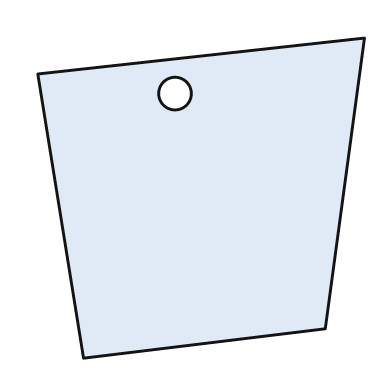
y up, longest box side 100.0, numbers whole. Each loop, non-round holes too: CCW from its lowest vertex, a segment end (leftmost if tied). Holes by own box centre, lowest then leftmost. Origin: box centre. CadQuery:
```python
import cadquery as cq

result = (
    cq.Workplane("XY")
    .moveTo(-36.0, -49.0)
    .lineTo(38.0, -40.0)
    .lineTo(50.0, 49.0)
    .lineTo(-50.0, 38.0)
    .close()
    .moveTo(-8.0, 32.0)
    .circle(5.0)
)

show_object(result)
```